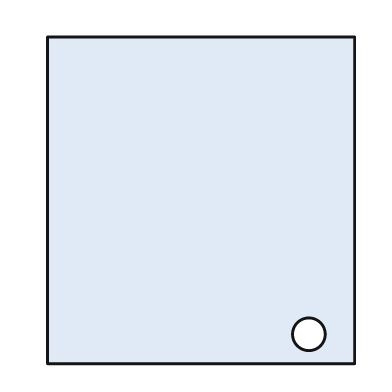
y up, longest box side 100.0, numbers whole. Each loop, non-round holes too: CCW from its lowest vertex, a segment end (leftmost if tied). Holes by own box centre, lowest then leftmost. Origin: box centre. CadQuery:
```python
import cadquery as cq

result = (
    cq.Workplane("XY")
    .moveTo(-47.0, -50.0)
    .lineTo(47.0, -50.0)
    .lineTo(47.0, 50.0)
    .lineTo(-47.0, 50.0)
    .close()
    .moveTo(33.0, -41.0)
    .circle(5.0)
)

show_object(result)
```